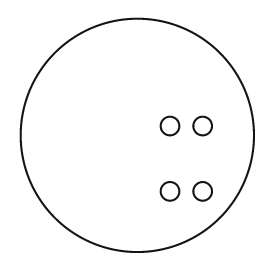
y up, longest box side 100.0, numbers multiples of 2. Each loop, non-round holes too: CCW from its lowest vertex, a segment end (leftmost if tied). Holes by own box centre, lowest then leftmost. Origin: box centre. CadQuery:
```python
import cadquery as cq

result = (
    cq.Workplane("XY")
    .moveTo(0.0, 0.0)
    .circle(50.0)
    .moveTo(14.0, -24.0)
    .circle(4.0)
    .moveTo(28.0, -24.0)
    .circle(4.0)
    .moveTo(14.0, 4.0)
    .circle(4.0)
    .moveTo(28.0, 4.0)
    .circle(4.0)
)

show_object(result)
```